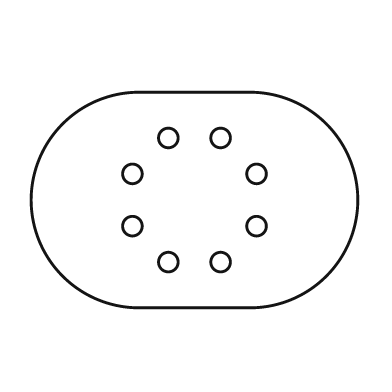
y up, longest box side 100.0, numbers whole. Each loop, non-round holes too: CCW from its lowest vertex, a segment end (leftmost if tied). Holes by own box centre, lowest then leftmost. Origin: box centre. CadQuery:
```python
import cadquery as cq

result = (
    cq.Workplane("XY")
    .moveTo(-17.0, -33.0)
    .lineTo(17.0, -33.0)
    .threePointArc((50.0, 0.0), (17.0, 33.0))
    .lineTo(-17.0, 33.0)
    .threePointArc((-50.0, 0.0), (-17.0, -33.0))
    .close()
    .moveTo(-8.0, -19.0)
    .circle(3.0)
    .moveTo(8.0, -19.0)
    .circle(3.0)
    .moveTo(-19.0, -8.0)
    .circle(3.0)
    .moveTo(19.0, -8.0)
    .circle(3.0)
    .moveTo(-19.0, 8.0)
    .circle(3.0)
    .moveTo(19.0, 8.0)
    .circle(3.0)
    .moveTo(-8.0, 19.0)
    .circle(3.0)
    .moveTo(8.0, 19.0)
    .circle(3.0)
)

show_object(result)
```